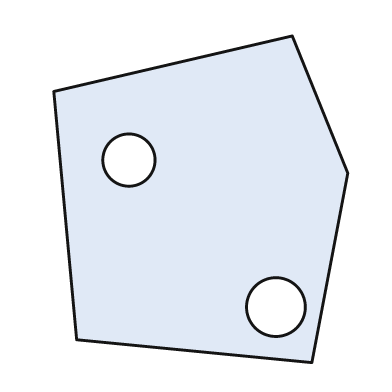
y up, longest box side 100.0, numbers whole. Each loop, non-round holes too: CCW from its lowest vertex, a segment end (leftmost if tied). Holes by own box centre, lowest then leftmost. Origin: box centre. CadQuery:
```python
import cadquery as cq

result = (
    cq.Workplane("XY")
    .moveTo(34.0, -50.0)
    .lineTo(45.0, 8.0)
    .lineTo(28.0, 50.0)
    .lineTo(-45.0, 33.0)
    .lineTo(-38.0, -43.0)
    .close()
    .moveTo(23.0, -33.0)
    .circle(9.0)
    .moveTo(-22.0, 12.0)
    .circle(8.0)
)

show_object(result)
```